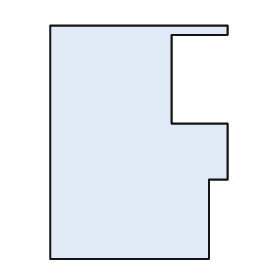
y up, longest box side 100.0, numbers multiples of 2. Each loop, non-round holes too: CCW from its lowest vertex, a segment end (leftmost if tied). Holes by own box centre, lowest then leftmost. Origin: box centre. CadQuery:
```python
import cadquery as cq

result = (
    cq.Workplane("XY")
    .moveTo(-38.0, -50.0)
    .lineTo(30.0, -50.0)
    .lineTo(30.0, -16.0)
    .lineTo(38.0, -16.0)
    .lineTo(38.0, 8.0)
    .lineTo(14.0, 8.0)
    .lineTo(14.0, 46.0)
    .lineTo(38.0, 46.0)
    .lineTo(38.0, 50.0)
    .lineTo(-38.0, 50.0)
    .close()
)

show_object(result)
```